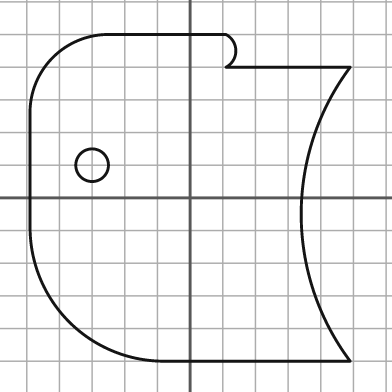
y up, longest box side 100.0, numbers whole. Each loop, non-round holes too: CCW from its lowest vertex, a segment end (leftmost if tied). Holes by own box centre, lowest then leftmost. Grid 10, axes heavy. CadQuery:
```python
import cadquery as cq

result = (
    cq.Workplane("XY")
    .moveTo(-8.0, -50.0)
    .lineTo(49.0, -50.0)
    .threePointArc((34.0, -5.0), (49.0, 40.0))
    .lineTo(11.0, 40.0)
    .threePointArc((14.0, 45.0), (11.0, 50.0))
    .lineTo(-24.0, 50.0)
    .threePointArc((-42.0, 43.0), (-49.0, 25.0))
    .lineTo(-49.0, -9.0)
    .threePointArc((-37.0, -38.0), (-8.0, -50.0))
    .close()
    .moveTo(-30.0, 10.0)
    .circle(5.0)
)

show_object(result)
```